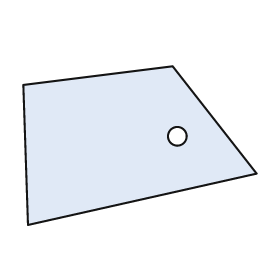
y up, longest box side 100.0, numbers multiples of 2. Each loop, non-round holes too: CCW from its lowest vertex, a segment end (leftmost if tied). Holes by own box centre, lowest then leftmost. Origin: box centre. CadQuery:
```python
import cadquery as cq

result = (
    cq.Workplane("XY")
    .moveTo(-48.0, -34.0)
    .lineTo(50.0, -12.0)
    .lineTo(14.0, 34.0)
    .lineTo(-50.0, 26.0)
    .close()
    .moveTo(16.0, 4.0)
    .circle(4.0)
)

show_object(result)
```